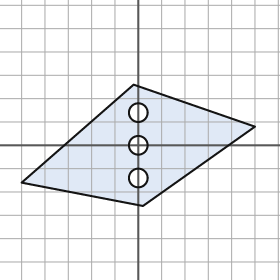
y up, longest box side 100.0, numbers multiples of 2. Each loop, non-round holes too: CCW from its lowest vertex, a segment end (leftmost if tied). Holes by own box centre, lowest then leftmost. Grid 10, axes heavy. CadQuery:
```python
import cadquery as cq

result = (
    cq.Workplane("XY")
    .moveTo(2.0, -26.0)
    .lineTo(50.0, 8.0)
    .lineTo(-2.0, 26.0)
    .lineTo(-50.0, -16.0)
    .close()
    .moveTo(0.0, -14.0)
    .circle(4.0)
    .moveTo(0.0, 0.0)
    .circle(4.0)
    .moveTo(0.0, 14.0)
    .circle(4.0)
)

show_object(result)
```